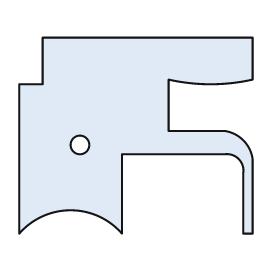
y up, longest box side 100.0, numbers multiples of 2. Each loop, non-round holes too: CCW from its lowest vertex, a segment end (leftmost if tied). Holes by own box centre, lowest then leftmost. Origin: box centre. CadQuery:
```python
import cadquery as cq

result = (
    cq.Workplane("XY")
    .moveTo(-50.0, -42.0)
    .threePointArc((-28.0, -32.0), (-6.0, -42.0))
    .lineTo(-6.0, -8.0)
    .lineTo(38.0, -8.0)
    .threePointArc((44.0, -10.0), (46.0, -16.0))
    .lineTo(46.0, -42.0)
    .lineTo(50.0, -42.0)
    .lineTo(50.0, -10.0)
    .threePointArc((46.0, -2.0), (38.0, 2.0))
    .lineTo(14.0, 2.0)
    .lineTo(14.0, 24.0)
    .threePointArc((32.0, 22.0), (50.0, 24.0))
    .lineTo(50.0, 42.0)
    .lineTo(-40.0, 42.0)
    .lineTo(-40.0, 22.0)
    .lineTo(-50.0, 22.0)
    .close()
    .moveTo(-24.0, -4.0)
    .circle(4.0)
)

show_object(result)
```